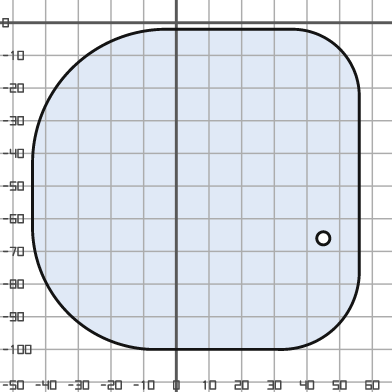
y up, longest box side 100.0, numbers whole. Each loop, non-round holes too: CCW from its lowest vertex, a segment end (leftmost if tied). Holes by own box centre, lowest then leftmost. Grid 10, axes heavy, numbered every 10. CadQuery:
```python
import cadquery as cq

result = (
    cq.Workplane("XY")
    .moveTo(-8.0, -100.0)
    .lineTo(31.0, -100.0)
    .threePointArc((49.0, -93.0), (56.0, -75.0))
    .lineTo(56.0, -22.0)
    .threePointArc((50.0, -8.0), (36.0, -2.0))
    .lineTo(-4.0, -2.0)
    .threePointArc((-32.0, -14.0), (-44.0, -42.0))
    .lineTo(-44.0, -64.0)
    .threePointArc((-33.0, -89.0), (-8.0, -100.0))
    .close()
    .moveTo(45.0, -66.0)
    .circle(2.0)
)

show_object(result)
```